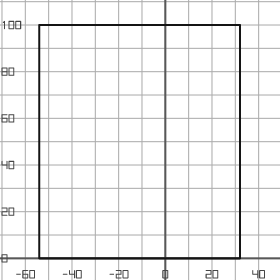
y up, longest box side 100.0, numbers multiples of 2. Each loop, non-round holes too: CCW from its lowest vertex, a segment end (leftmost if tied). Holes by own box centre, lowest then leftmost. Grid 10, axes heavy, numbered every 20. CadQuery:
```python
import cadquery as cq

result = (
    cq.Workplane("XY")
    .moveTo(-54.0, 0.0)
    .lineTo(32.0, 0.0)
    .lineTo(32.0, 100.0)
    .lineTo(-54.0, 100.0)
    .close()
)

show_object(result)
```